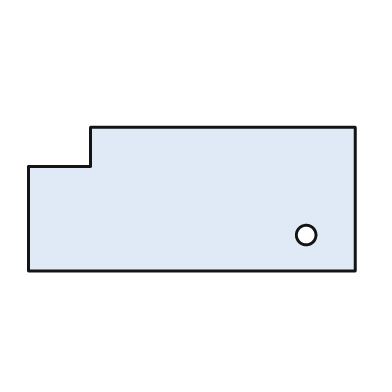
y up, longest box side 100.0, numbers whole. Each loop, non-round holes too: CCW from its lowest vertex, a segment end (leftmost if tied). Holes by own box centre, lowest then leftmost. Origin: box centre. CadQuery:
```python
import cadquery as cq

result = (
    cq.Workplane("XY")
    .moveTo(-50.0, -22.0)
    .lineTo(50.0, -22.0)
    .lineTo(50.0, 22.0)
    .lineTo(-31.0, 22.0)
    .lineTo(-31.0, 10.0)
    .lineTo(-50.0, 10.0)
    .close()
    .moveTo(35.0, -11.0)
    .circle(3.0)
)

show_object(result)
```